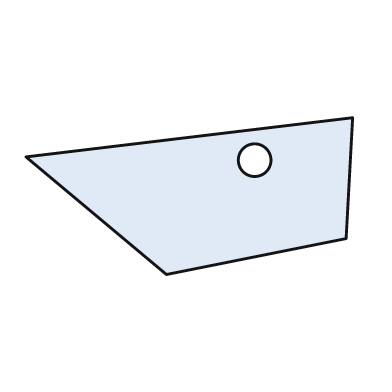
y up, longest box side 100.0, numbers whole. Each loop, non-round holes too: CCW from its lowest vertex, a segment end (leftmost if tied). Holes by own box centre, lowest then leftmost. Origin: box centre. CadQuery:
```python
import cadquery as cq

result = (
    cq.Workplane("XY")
    .moveTo(-7.0, -24.0)
    .lineTo(48.0, -13.0)
    .lineTo(50.0, 24.0)
    .lineTo(-50.0, 12.0)
    .close()
    .moveTo(20.0, 11.0)
    .circle(5.0)
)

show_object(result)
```